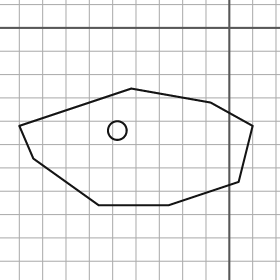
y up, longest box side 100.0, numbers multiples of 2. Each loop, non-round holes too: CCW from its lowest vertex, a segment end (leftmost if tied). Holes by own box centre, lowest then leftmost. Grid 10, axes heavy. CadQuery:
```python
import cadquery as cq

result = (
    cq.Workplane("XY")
    .moveTo(-56.0, -76.0)
    .lineTo(-26.0, -76.0)
    .lineTo(4.0, -66.0)
    .lineTo(10.0, -42.0)
    .lineTo(-8.0, -32.0)
    .lineTo(-42.0, -26.0)
    .lineTo(-90.0, -42.0)
    .lineTo(-84.0, -56.0)
    .close()
    .moveTo(-48.0, -44.0)
    .circle(4.0)
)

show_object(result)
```